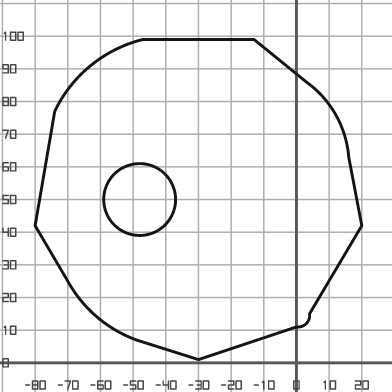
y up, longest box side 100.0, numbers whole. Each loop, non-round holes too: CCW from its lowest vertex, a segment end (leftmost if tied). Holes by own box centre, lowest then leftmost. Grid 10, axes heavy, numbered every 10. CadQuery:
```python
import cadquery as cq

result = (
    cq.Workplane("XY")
    .moveTo(-30.0, 1.0)
    .lineTo(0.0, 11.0)
    .threePointArc((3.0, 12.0), (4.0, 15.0))
    .lineTo(20.0, 42.0)
    .lineTo(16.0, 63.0)
    .threePointArc((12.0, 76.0), (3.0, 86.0))
    .lineTo(-13.0, 99.0)
    .lineTo(-47.0, 99.0)
    .threePointArc((-63.0, 91.0), (-74.0, 77.0))
    .lineTo(-80.0, 42.0)
    .lineTo(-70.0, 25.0)
    .threePointArc((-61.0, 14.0), (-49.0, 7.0))
    .close()
    .moveTo(-48.0, 50.0)
    .circle(11.0)
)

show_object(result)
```